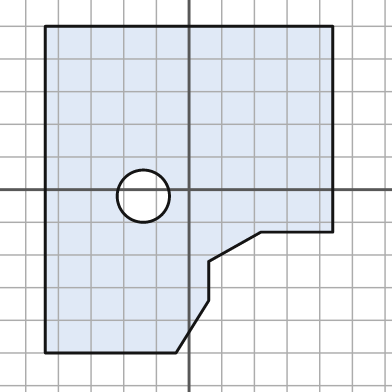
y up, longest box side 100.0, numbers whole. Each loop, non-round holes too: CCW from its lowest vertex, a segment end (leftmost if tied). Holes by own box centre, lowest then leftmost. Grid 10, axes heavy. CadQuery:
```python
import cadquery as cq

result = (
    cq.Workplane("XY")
    .moveTo(-44.0, -50.0)
    .lineTo(-4.0, -50.0)
    .lineTo(6.0, -34.0)
    .lineTo(6.0, -22.0)
    .lineTo(22.0, -13.0)
    .lineTo(44.0, -13.0)
    .lineTo(44.0, 50.0)
    .lineTo(-44.0, 50.0)
    .close()
    .moveTo(-14.0, -2.0)
    .circle(8.0)
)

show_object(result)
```